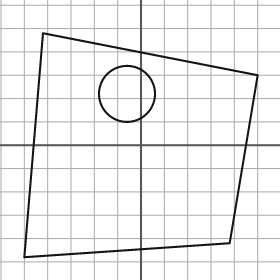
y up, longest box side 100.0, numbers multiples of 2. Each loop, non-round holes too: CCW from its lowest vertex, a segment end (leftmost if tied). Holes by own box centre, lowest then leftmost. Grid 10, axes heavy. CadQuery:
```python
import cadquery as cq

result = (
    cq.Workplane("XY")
    .moveTo(-50.0, -48.0)
    .lineTo(38.0, -42.0)
    .lineTo(50.0, 30.0)
    .lineTo(-42.0, 48.0)
    .close()
    .moveTo(-6.0, 22.0)
    .circle(12.0)
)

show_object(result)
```